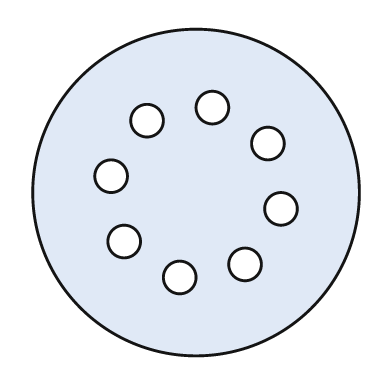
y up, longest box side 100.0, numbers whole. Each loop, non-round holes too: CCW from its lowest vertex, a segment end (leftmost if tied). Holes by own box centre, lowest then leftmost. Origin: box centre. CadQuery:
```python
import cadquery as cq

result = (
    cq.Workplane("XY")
    .moveTo(0.0, 0.0)
    .circle(50.0)
    .moveTo(-5.0, -26.0)
    .circle(5.0)
    .moveTo(15.0, -22.0)
    .circle(5.0)
    .moveTo(-22.0, -15.0)
    .circle(5.0)
    .moveTo(26.0, -5.0)
    .circle(5.0)
    .moveTo(-26.0, 5.0)
    .circle(5.0)
    .moveTo(22.0, 15.0)
    .circle(5.0)
    .moveTo(-15.0, 22.0)
    .circle(5.0)
    .moveTo(5.0, 26.0)
    .circle(5.0)
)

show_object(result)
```